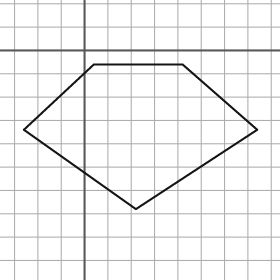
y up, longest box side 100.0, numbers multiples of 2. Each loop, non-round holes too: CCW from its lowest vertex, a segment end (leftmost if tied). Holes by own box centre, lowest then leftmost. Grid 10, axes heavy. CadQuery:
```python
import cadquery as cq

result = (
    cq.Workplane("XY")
    .moveTo(22.0, -68.0)
    .lineTo(74.0, -34.0)
    .lineTo(42.0, -6.0)
    .lineTo(4.0, -6.0)
    .lineTo(-26.0, -34.0)
    .close()
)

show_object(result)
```